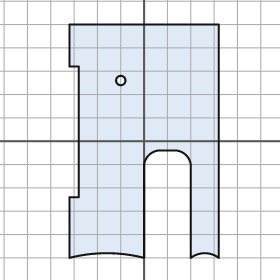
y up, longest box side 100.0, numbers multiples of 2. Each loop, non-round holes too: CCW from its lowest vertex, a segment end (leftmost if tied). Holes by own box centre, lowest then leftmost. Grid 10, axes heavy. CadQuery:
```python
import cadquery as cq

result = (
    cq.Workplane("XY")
    .moveTo(-32.0, -50.0)
    .threePointArc((-16.0, -48.0), (0.0, -50.0))
    .lineTo(0.0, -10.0)
    .threePointArc((2.0, -6.0), (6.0, -4.0))
    .lineTo(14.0, -4.0)
    .threePointArc((18.0, -6.0), (20.0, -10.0))
    .lineTo(20.0, -50.0)
    .threePointArc((26.0, -48.0), (32.0, -50.0))
    .lineTo(32.0, 50.0)
    .lineTo(-32.0, 50.0)
    .lineTo(-32.0, 32.0)
    .lineTo(-28.0, 32.0)
    .lineTo(-28.0, -24.0)
    .lineTo(-32.0, -24.0)
    .close()
    .moveTo(-10.0, 26.0)
    .circle(2.0)
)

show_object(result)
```